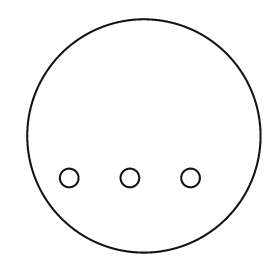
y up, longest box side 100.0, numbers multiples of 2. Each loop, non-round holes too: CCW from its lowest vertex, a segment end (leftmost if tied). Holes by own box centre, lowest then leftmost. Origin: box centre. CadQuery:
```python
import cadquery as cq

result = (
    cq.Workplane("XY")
    .moveTo(0.0, 0.0)
    .circle(50.0)
    .moveTo(-32.0, -18.0)
    .circle(4.0)
    .moveTo(-6.0, -18.0)
    .circle(4.0)
    .moveTo(20.0, -18.0)
    .circle(4.0)
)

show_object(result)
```